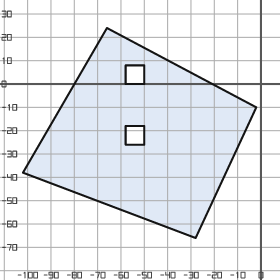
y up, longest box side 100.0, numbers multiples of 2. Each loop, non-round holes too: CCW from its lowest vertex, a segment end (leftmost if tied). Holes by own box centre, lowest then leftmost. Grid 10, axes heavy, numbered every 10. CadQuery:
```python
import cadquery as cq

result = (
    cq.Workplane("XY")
    .moveTo(-28.0, -66.0)
    .lineTo(-2.0, -10.0)
    .lineTo(-66.0, 24.0)
    .lineTo(-102.0, -38.0)
    .close()
    .moveTo(-58.0, -26.0)
    .lineTo(-50.0, -26.0)
    .lineTo(-50.0, -18.0)
    .lineTo(-58.0, -18.0)
    .close()
    .moveTo(-58.0, 0.0)
    .lineTo(-50.0, 0.0)
    .lineTo(-50.0, 8.0)
    .lineTo(-58.0, 8.0)
    .close()
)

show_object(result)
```